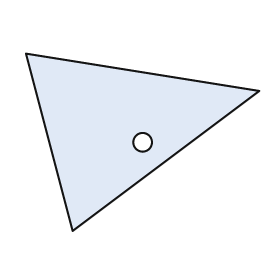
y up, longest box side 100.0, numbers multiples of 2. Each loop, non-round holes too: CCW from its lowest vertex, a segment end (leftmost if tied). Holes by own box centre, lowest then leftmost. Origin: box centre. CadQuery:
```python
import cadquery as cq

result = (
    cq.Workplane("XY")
    .moveTo(-30.0, -38.0)
    .lineTo(50.0, 22.0)
    .lineTo(-50.0, 38.0)
    .close()
    .moveTo(0.0, 0.0)
    .circle(4.0)
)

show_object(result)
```